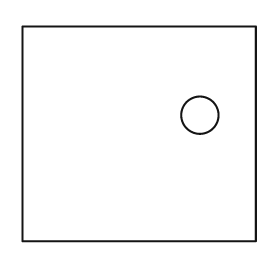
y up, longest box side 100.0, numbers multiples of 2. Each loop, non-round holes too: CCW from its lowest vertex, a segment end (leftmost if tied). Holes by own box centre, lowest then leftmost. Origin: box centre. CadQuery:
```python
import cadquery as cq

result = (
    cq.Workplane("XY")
    .moveTo(-50.0, -46.0)
    .lineTo(50.0, -46.0)
    .lineTo(50.0, 46.0)
    .lineTo(-50.0, 46.0)
    .close()
    .moveTo(26.0, 8.0)
    .circle(8.0)
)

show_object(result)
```